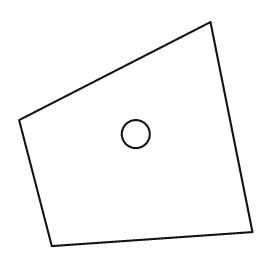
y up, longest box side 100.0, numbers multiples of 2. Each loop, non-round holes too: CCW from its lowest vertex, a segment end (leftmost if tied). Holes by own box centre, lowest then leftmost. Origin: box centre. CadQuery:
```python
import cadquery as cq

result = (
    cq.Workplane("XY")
    .moveTo(-36.0, -48.0)
    .lineTo(50.0, -42.0)
    .lineTo(32.0, 48.0)
    .lineTo(-50.0, 6.0)
    .close()
    .moveTo(0.0, 0.0)
    .circle(6.0)
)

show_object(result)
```